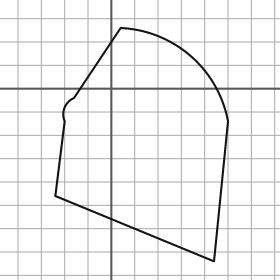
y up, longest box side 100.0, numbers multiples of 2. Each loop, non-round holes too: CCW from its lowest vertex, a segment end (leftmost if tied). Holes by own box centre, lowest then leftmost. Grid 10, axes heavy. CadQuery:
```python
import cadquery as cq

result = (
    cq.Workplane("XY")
    .moveTo(44.0, -74.0)
    .lineTo(50.0, -14.0)
    .threePointArc((34.0, 14.0), (4.0, 26.0))
    .lineTo(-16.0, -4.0)
    .threePointArc((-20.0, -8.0), (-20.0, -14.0))
    .lineTo(-24.0, -46.0)
    .close()
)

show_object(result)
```